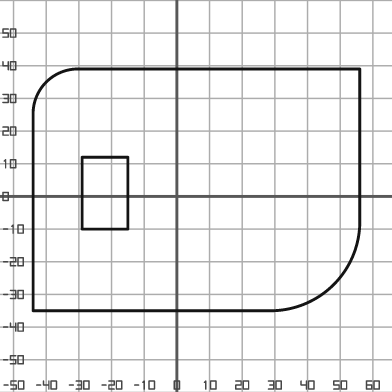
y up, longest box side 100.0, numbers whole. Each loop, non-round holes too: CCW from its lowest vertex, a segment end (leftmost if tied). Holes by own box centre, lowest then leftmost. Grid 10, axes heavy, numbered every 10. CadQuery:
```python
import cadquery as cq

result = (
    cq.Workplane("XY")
    .moveTo(-44.0, -35.0)
    .lineTo(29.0, -35.0)
    .threePointArc((48.0, -27.0), (56.0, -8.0))
    .lineTo(56.0, 39.0)
    .lineTo(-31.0, 39.0)
    .threePointArc((-40.0, 35.0), (-44.0, 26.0))
    .close()
    .moveTo(-29.0, -10.0)
    .lineTo(-15.0, -10.0)
    .lineTo(-15.0, 12.0)
    .lineTo(-29.0, 12.0)
    .close()
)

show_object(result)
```